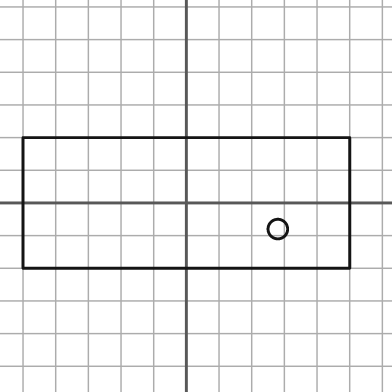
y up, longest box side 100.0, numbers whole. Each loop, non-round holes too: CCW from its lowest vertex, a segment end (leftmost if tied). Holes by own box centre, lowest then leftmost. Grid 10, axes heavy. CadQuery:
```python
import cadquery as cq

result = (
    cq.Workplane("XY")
    .moveTo(-50.0, -20.0)
    .lineTo(50.0, -20.0)
    .lineTo(50.0, 20.0)
    .lineTo(-50.0, 20.0)
    .close()
    .moveTo(28.0, -8.0)
    .circle(3.0)
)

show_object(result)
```